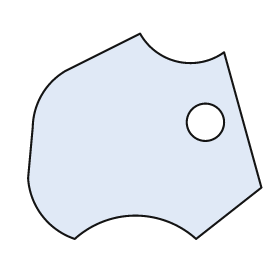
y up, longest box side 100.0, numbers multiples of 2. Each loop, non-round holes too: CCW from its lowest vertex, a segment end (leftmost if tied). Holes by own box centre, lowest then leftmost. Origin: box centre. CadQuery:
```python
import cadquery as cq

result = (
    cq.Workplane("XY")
    .moveTo(-30.0, -44.0)
    .threePointArc((-4.0, -34.0), (22.0, -44.0))
    .lineTo(50.0, -22.0)
    .lineTo(34.0, 36.0)
    .threePointArc((14.0, 32.0), (-2.0, 44.0))
    .lineTo(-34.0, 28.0)
    .threePointArc((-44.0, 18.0), (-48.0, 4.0))
    .lineTo(-50.0, -18.0)
    .threePointArc((-44.0, -34.0), (-30.0, -44.0))
    .close()
    .moveTo(26.0, 6.0)
    .circle(8.0)
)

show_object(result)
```